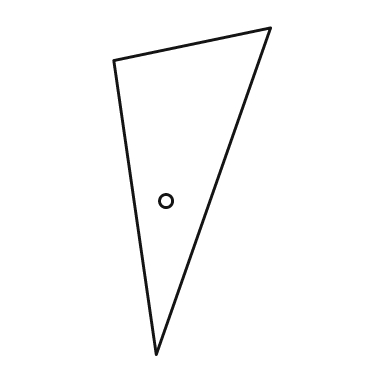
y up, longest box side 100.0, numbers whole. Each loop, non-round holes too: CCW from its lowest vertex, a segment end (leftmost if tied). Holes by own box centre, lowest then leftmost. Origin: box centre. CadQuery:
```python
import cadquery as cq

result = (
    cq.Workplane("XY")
    .moveTo(-11.0, -50.0)
    .lineTo(24.0, 50.0)
    .lineTo(-24.0, 40.0)
    .close()
    .moveTo(-8.0, -3.0)
    .circle(2.0)
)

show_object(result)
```